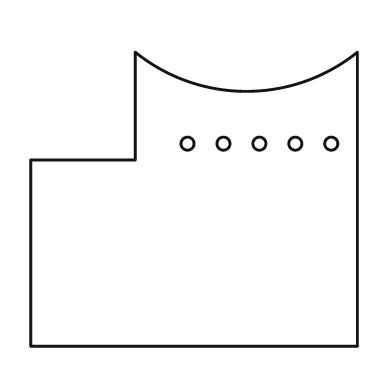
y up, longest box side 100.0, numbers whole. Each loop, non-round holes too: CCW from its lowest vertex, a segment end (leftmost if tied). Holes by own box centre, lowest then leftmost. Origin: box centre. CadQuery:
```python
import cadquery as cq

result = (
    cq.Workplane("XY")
    .moveTo(-50.0, -45.0)
    .lineTo(50.0, -45.0)
    .lineTo(50.0, 45.0)
    .threePointArc((16.0, 33.0), (-18.0, 45.0))
    .lineTo(-18.0, 12.0)
    .lineTo(-50.0, 12.0)
    .close()
    .moveTo(-2.0, 17.0)
    .circle(2.0)
    .moveTo(9.0, 17.0)
    .circle(2.0)
    .moveTo(20.0, 17.0)
    .circle(2.0)
    .moveTo(31.0, 17.0)
    .circle(2.0)
    .moveTo(42.0, 17.0)
    .circle(2.0)
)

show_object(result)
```